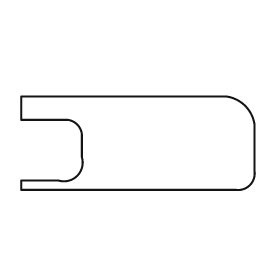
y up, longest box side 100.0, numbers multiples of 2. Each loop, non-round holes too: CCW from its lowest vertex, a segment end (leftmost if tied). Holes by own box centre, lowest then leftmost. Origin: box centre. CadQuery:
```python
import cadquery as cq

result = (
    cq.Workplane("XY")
    .moveTo(-50.0, -20.0)
    .lineTo(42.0, -20.0)
    .threePointArc((48.0, -18.0), (50.0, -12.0))
    .lineTo(50.0, 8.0)
    .threePointArc((46.0, 16.0), (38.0, 20.0))
    .lineTo(-50.0, 20.0)
    .lineTo(-50.0, 10.0)
    .lineTo(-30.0, 10.0)
    .threePointArc((-26.0, 8.0), (-24.0, 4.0))
    .lineTo(-24.0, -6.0)
    .threePointArc((-26.0, -14.0), (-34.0, -16.0))
    .lineTo(-50.0, -16.0)
    .close()
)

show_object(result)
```